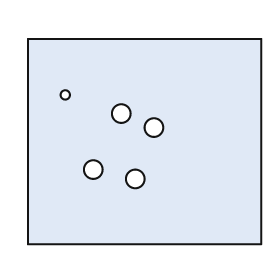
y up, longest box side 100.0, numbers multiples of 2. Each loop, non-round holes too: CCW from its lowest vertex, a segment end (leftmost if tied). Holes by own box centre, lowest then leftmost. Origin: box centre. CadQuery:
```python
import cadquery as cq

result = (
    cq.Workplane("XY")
    .moveTo(-50.0, -44.0)
    .lineTo(50.0, -44.0)
    .lineTo(50.0, 44.0)
    .lineTo(-50.0, 44.0)
    .close()
    .moveTo(-4.0, -16.0)
    .circle(4.0)
    .moveTo(-22.0, -12.0)
    .circle(4.0)
    .moveTo(4.0, 6.0)
    .circle(4.0)
    .moveTo(-10.0, 12.0)
    .circle(4.0)
    .moveTo(-34.0, 20.0)
    .circle(2.0)
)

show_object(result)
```